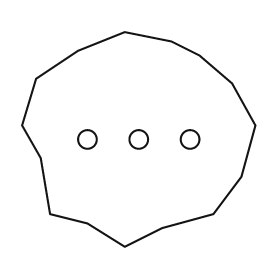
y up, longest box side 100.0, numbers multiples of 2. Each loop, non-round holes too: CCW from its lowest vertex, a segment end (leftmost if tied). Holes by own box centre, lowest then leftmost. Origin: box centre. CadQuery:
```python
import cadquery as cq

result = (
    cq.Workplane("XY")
    .moveTo(-6.0, -46.0)
    .lineTo(10.0, -38.0)
    .lineTo(32.0, -32.0)
    .lineTo(44.0, -16.0)
    .lineTo(50.0, 6.0)
    .lineTo(40.0, 24.0)
    .lineTo(26.0, 36.0)
    .lineTo(14.0, 42.0)
    .lineTo(-6.0, 46.0)
    .lineTo(-26.0, 38.0)
    .lineTo(-44.0, 26.0)
    .lineTo(-50.0, 6.0)
    .lineTo(-42.0, -8.0)
    .lineTo(-38.0, -32.0)
    .lineTo(-22.0, -36.0)
    .close()
    .moveTo(-22.0, 0.0)
    .circle(4.0)
    .moveTo(0.0, 0.0)
    .circle(4.0)
    .moveTo(22.0, 0.0)
    .circle(4.0)
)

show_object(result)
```